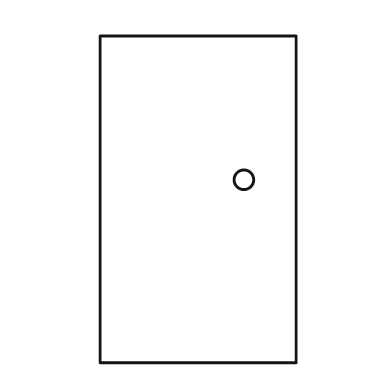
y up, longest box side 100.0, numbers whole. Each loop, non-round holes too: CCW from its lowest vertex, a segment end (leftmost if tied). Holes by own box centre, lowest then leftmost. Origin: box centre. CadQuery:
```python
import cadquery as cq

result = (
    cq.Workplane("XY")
    .moveTo(-30.0, -50.0)
    .lineTo(30.0, -50.0)
    .lineTo(30.0, 50.0)
    .lineTo(-30.0, 50.0)
    .close()
    .moveTo(14.0, 6.0)
    .circle(3.0)
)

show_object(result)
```